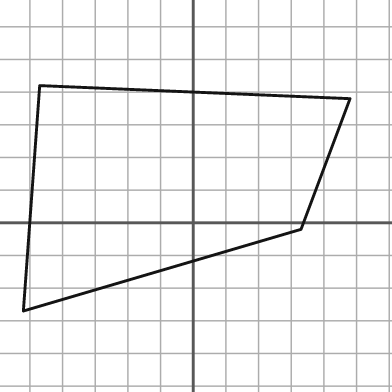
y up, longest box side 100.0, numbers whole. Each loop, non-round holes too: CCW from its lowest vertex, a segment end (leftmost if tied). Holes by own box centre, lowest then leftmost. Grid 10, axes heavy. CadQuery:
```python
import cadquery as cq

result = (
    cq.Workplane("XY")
    .moveTo(-52.0, -27.0)
    .lineTo(33.0, -2.0)
    .lineTo(48.0, 38.0)
    .lineTo(-47.0, 42.0)
    .close()
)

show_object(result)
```